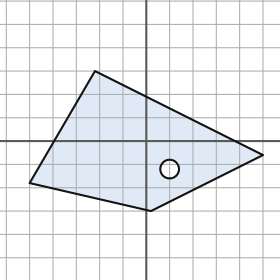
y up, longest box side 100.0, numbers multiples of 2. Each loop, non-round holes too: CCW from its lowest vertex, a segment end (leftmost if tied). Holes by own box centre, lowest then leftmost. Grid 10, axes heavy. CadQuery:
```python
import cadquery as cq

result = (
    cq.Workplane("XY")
    .moveTo(2.0, -30.0)
    .lineTo(50.0, -6.0)
    .lineTo(-22.0, 30.0)
    .lineTo(-50.0, -18.0)
    .close()
    .moveTo(10.0, -12.0)
    .circle(4.0)
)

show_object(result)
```